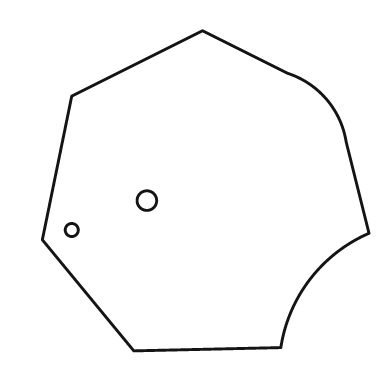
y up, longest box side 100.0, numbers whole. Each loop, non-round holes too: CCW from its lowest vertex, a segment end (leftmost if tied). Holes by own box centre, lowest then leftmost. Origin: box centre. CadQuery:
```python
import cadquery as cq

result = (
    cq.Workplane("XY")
    .moveTo(-22.0, -49.0)
    .lineTo(23.0, -48.0)
    .threePointArc((32.0, -27.0), (50.0, -13.0))
    .lineTo(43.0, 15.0)
    .threePointArc((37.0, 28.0), (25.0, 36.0))
    .lineTo(-1.0, 49.0)
    .lineTo(-41.0, 29.0)
    .lineTo(-50.0, -15.0)
    .close()
    .moveTo(-41.0, -12.0)
    .circle(2.0)
    .moveTo(-18.0, -3.0)
    .circle(3.0)
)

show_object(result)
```